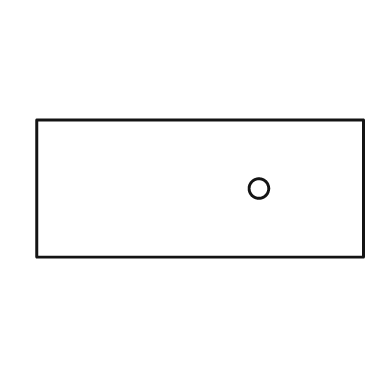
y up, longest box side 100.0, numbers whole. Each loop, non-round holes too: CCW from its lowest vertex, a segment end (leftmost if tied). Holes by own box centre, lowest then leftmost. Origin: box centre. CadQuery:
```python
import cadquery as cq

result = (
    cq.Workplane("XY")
    .moveTo(-50.0, -21.0)
    .lineTo(50.0, -21.0)
    .lineTo(50.0, 21.0)
    .lineTo(-50.0, 21.0)
    .close()
    .moveTo(18.0, 0.0)
    .circle(3.0)
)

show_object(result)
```